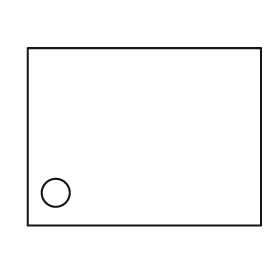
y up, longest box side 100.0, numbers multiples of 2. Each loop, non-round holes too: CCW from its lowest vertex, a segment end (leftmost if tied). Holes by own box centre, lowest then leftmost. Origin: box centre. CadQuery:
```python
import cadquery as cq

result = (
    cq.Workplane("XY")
    .moveTo(-50.0, -38.0)
    .lineTo(50.0, -38.0)
    .lineTo(50.0, 38.0)
    .lineTo(-50.0, 38.0)
    .close()
    .moveTo(-38.0, -24.0)
    .circle(6.0)
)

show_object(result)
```